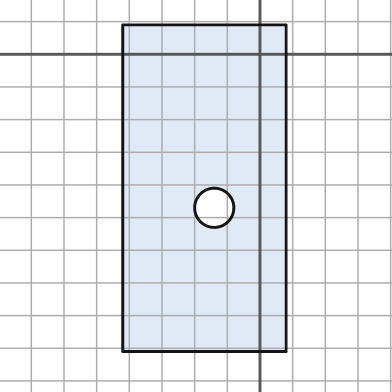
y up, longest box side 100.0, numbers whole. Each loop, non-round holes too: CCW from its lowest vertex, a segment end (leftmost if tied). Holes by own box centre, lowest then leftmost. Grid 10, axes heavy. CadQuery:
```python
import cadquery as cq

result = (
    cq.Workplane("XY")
    .moveTo(-42.0, -91.0)
    .lineTo(8.0, -91.0)
    .lineTo(8.0, 9.0)
    .lineTo(-42.0, 9.0)
    .close()
    .moveTo(-14.0, -47.0)
    .circle(6.0)
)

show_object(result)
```